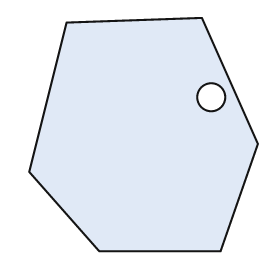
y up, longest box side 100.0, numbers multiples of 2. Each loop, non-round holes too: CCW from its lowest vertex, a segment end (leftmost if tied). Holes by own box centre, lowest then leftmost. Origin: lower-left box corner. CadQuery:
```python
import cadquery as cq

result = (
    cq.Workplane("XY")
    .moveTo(30.0, 0.0)
    .lineTo(82.0, 0.0)
    .lineTo(98.0, 46.0)
    .lineTo(74.0, 100.0)
    .lineTo(16.0, 98.0)
    .lineTo(0.0, 34.0)
    .close()
    .moveTo(78.0, 66.0)
    .circle(6.0)
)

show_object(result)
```